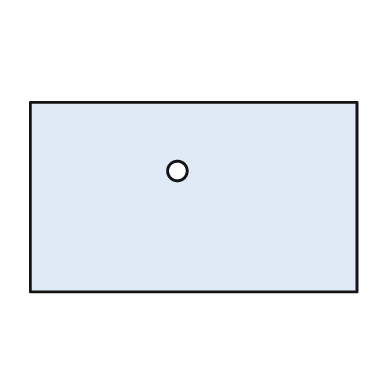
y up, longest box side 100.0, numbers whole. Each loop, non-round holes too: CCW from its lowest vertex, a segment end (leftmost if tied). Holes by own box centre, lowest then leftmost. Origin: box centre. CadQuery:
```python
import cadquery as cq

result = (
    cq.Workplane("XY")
    .moveTo(-50.0, -29.0)
    .lineTo(50.0, -29.0)
    .lineTo(50.0, 29.0)
    .lineTo(-50.0, 29.0)
    .close()
    .moveTo(-5.0, 8.0)
    .circle(3.0)
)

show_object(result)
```